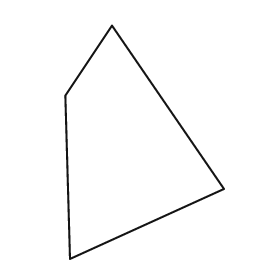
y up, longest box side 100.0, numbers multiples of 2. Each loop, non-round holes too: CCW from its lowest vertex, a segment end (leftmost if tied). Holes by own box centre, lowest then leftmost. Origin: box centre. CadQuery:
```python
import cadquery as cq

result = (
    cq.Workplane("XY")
    .moveTo(-32.0, -50.0)
    .lineTo(34.0, -20.0)
    .lineTo(-14.0, 50.0)
    .lineTo(-34.0, 20.0)
    .close()
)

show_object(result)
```